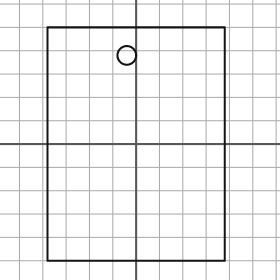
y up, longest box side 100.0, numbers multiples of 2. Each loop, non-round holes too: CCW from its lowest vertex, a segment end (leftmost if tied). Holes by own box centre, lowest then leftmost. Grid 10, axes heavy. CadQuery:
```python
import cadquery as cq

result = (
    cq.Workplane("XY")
    .moveTo(-38.0, -50.0)
    .lineTo(38.0, -50.0)
    .lineTo(38.0, 50.0)
    .lineTo(-38.0, 50.0)
    .close()
    .moveTo(-4.0, 38.0)
    .circle(4.0)
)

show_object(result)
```